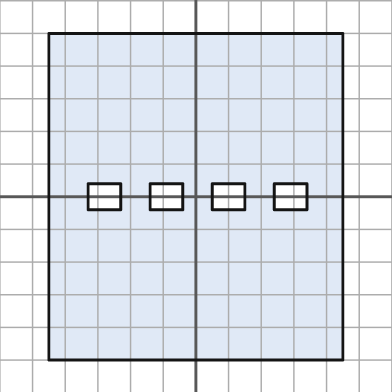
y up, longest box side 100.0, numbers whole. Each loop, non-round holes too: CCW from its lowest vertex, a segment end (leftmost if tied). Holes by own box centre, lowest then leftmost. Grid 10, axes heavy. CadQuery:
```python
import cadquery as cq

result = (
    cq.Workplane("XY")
    .moveTo(-45.0, -50.0)
    .lineTo(45.0, -50.0)
    .lineTo(45.0, 50.0)
    .lineTo(-45.0, 50.0)
    .close()
    .moveTo(-33.0, -4.0)
    .lineTo(-23.0, -4.0)
    .lineTo(-23.0, 4.0)
    .lineTo(-33.0, 4.0)
    .close()
    .moveTo(-14.0, -4.0)
    .lineTo(-4.0, -4.0)
    .lineTo(-4.0, 4.0)
    .lineTo(-14.0, 4.0)
    .close()
    .moveTo(5.0, -4.0)
    .lineTo(15.0, -4.0)
    .lineTo(15.0, 4.0)
    .lineTo(5.0, 4.0)
    .close()
    .moveTo(24.0, -4.0)
    .lineTo(34.0, -4.0)
    .lineTo(34.0, 4.0)
    .lineTo(24.0, 4.0)
    .close()
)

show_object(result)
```